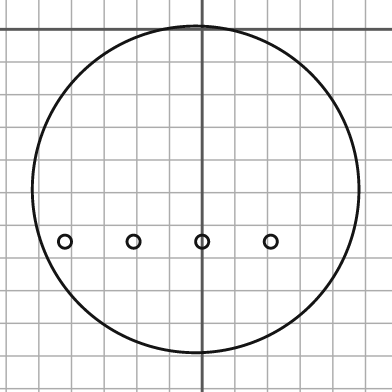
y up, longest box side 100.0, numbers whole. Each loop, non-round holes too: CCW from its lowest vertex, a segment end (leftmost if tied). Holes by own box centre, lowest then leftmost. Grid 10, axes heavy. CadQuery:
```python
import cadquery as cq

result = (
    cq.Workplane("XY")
    .moveTo(-2.0, -49.0)
    .circle(50.0)
    .moveTo(-42.0, -65.0)
    .circle(2.0)
    .moveTo(-21.0, -65.0)
    .circle(2.0)
    .moveTo(0.0, -65.0)
    .circle(2.0)
    .moveTo(21.0, -65.0)
    .circle(2.0)
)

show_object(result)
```